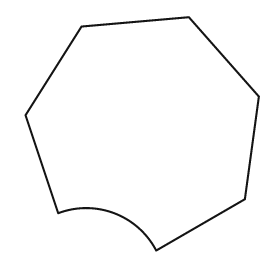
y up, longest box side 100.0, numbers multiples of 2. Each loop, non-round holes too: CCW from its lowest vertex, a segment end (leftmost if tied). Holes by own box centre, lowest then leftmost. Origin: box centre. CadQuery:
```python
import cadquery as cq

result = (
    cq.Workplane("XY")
    .moveTo(6.0, -50.0)
    .lineTo(44.0, -28.0)
    .lineTo(50.0, 16.0)
    .lineTo(20.0, 50.0)
    .lineTo(-26.0, 46.0)
    .lineTo(-50.0, 8.0)
    .lineTo(-36.0, -34.0)
    .threePointArc((-12.0, -34.0), (6.0, -50.0))
    .close()
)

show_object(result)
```